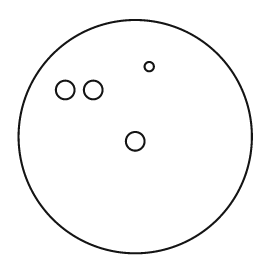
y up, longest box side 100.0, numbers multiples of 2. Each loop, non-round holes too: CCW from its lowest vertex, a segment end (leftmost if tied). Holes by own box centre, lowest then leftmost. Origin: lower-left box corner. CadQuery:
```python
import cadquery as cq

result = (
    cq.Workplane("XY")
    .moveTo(50.0, 50.0)
    .circle(50.0)
    .moveTo(50.0, 48.0)
    .circle(4.0)
    .moveTo(20.0, 70.0)
    .circle(4.0)
    .moveTo(32.0, 70.0)
    .circle(4.0)
    .moveTo(56.0, 80.0)
    .circle(2.0)
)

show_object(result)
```